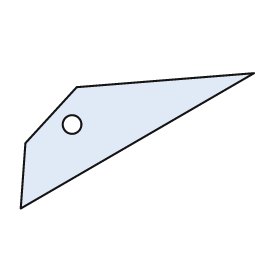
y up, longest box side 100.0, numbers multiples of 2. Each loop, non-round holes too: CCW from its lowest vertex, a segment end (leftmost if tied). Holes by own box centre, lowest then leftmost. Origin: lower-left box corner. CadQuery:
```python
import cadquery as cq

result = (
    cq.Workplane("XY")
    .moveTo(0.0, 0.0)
    .lineTo(100.0, 58.0)
    .lineTo(24.0, 52.0)
    .lineTo(2.0, 28.0)
    .close()
    .moveTo(22.0, 36.0)
    .circle(4.0)
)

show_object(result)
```